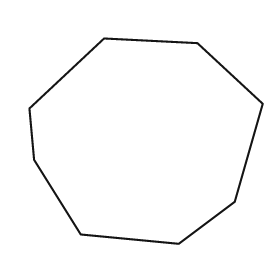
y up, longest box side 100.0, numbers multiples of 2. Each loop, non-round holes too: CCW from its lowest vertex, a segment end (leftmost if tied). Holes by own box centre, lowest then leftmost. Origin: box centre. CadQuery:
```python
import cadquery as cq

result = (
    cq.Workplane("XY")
    .moveTo(14.0, -44.0)
    .lineTo(38.0, -26.0)
    .lineTo(50.0, 16.0)
    .lineTo(22.0, 42.0)
    .lineTo(-18.0, 44.0)
    .lineTo(-50.0, 14.0)
    .lineTo(-48.0, -8.0)
    .lineTo(-28.0, -40.0)
    .close()
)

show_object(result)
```